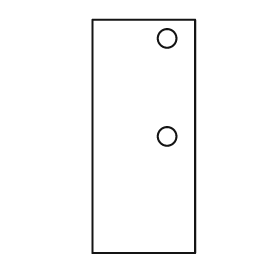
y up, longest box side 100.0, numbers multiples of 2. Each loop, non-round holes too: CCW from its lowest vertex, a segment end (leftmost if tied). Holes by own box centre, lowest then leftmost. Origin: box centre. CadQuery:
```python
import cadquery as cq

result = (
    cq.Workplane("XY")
    .moveTo(-22.0, -50.0)
    .lineTo(22.0, -50.0)
    .lineTo(22.0, 50.0)
    .lineTo(-22.0, 50.0)
    .close()
    .moveTo(10.0, 0.0)
    .circle(4.0)
    .moveTo(10.0, 42.0)
    .circle(4.0)
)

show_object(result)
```